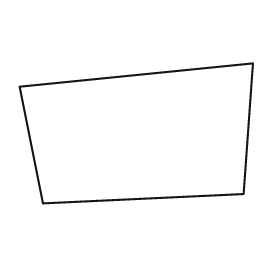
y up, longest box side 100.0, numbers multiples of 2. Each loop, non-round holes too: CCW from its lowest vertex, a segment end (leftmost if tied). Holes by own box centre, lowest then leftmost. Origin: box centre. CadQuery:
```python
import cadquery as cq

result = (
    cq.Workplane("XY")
    .moveTo(-40.0, -30.0)
    .lineTo(46.0, -26.0)
    .lineTo(50.0, 30.0)
    .lineTo(-50.0, 20.0)
    .close()
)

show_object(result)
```